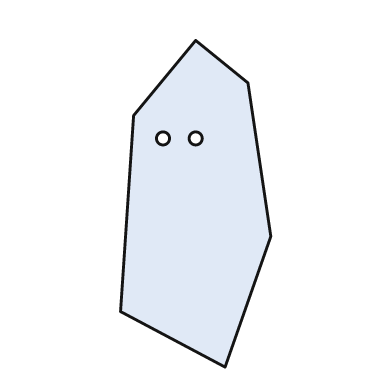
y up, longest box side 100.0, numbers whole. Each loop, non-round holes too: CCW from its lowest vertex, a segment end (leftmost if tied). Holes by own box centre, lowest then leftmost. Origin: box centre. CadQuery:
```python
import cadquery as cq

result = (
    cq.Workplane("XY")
    .moveTo(9.0, -50.0)
    .lineTo(23.0, -10.0)
    .lineTo(16.0, 37.0)
    .lineTo(0.0, 50.0)
    .lineTo(-19.0, 27.0)
    .lineTo(-23.0, -33.0)
    .close()
    .moveTo(-10.0, 20.0)
    .circle(2.0)
    .moveTo(0.0, 20.0)
    .circle(2.0)
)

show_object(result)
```